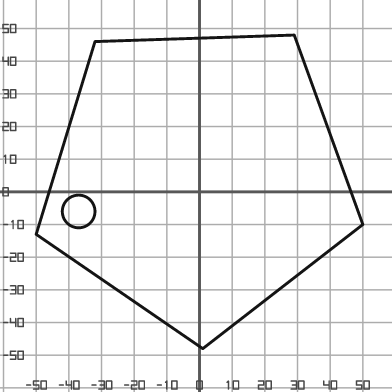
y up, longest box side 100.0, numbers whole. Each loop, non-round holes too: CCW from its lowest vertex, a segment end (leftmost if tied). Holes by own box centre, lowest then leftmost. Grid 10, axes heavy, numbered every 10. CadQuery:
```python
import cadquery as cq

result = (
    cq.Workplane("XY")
    .moveTo(1.0, -48.0)
    .lineTo(50.0, -10.0)
    .lineTo(29.0, 48.0)
    .lineTo(-32.0, 46.0)
    .lineTo(-50.0, -13.0)
    .close()
    .moveTo(-37.0, -6.0)
    .circle(5.0)
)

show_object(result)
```